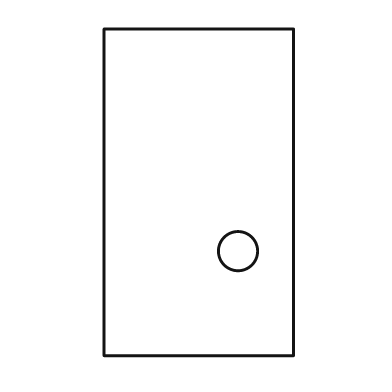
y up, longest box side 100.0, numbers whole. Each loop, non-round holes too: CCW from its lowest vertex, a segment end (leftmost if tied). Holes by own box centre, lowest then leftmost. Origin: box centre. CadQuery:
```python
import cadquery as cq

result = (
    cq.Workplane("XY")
    .moveTo(-29.0, -50.0)
    .lineTo(29.0, -50.0)
    .lineTo(29.0, 50.0)
    .lineTo(-29.0, 50.0)
    .close()
    .moveTo(12.0, -18.0)
    .circle(6.0)
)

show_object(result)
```